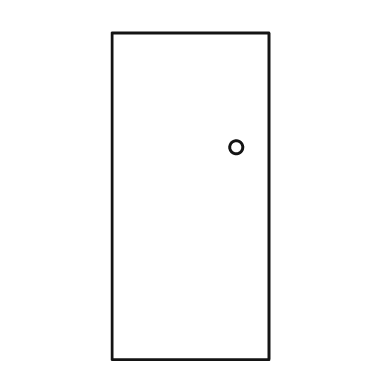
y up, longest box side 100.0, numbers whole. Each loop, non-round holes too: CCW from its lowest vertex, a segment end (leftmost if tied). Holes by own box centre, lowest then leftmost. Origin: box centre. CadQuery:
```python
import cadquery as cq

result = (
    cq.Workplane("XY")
    .moveTo(-24.0, -50.0)
    .lineTo(24.0, -50.0)
    .lineTo(24.0, 50.0)
    .lineTo(-24.0, 50.0)
    .close()
    .moveTo(14.0, 15.0)
    .circle(2.0)
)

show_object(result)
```